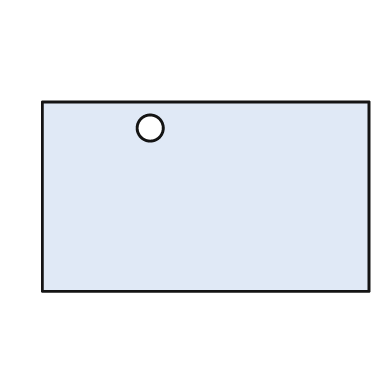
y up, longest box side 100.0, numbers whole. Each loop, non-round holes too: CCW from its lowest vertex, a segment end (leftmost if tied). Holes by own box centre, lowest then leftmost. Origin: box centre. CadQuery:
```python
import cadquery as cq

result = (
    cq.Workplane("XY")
    .moveTo(-50.0, -29.0)
    .lineTo(50.0, -29.0)
    .lineTo(50.0, 29.0)
    .lineTo(-50.0, 29.0)
    .close()
    .moveTo(-17.0, 21.0)
    .circle(4.0)
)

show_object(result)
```